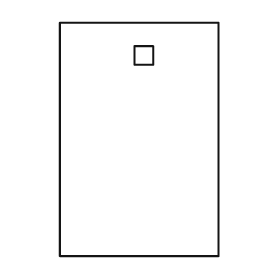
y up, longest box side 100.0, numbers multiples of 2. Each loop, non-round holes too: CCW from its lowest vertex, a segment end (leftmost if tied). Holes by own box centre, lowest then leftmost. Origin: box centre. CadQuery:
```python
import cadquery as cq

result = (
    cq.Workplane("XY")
    .moveTo(-34.0, -50.0)
    .lineTo(34.0, -50.0)
    .lineTo(34.0, 50.0)
    .lineTo(-34.0, 50.0)
    .close()
    .moveTo(-2.0, 32.0)
    .lineTo(6.0, 32.0)
    .lineTo(6.0, 40.0)
    .lineTo(-2.0, 40.0)
    .close()
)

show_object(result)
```